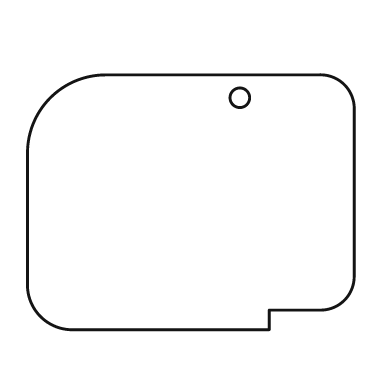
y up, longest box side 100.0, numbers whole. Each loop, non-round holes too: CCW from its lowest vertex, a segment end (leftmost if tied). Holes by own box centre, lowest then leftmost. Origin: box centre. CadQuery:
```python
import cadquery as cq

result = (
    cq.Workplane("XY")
    .moveTo(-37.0, -39.0)
    .lineTo(24.0, -39.0)
    .lineTo(24.0, -33.0)
    .lineTo(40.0, -33.0)
    .threePointArc((47.0, -30.0), (50.0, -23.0))
    .lineTo(50.0, 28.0)
    .threePointArc((47.0, 36.0), (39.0, 39.0))
    .lineTo(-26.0, 39.0)
    .threePointArc((-43.0, 32.0), (-50.0, 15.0))
    .lineTo(-50.0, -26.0)
    .threePointArc((-46.0, -35.0), (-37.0, -39.0))
    .close()
    .moveTo(15.0, 32.0)
    .circle(3.0)
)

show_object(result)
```